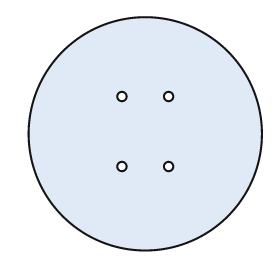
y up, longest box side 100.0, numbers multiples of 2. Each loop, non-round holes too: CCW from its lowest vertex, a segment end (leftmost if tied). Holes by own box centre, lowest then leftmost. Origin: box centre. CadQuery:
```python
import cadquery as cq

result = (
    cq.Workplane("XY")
    .moveTo(0.0, 0.0)
    .circle(50.0)
    .moveTo(-10.0, -14.0)
    .circle(2.0)
    .moveTo(10.0, -14.0)
    .circle(2.0)
    .moveTo(-10.0, 16.0)
    .circle(2.0)
    .moveTo(10.0, 16.0)
    .circle(2.0)
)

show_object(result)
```